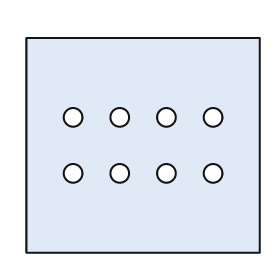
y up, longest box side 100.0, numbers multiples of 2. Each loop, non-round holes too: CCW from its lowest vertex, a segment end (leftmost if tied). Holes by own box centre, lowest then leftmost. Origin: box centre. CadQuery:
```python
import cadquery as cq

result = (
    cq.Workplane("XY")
    .moveTo(-50.0, -46.0)
    .lineTo(50.0, -46.0)
    .lineTo(50.0, 46.0)
    .lineTo(-50.0, 46.0)
    .close()
    .moveTo(-30.0, -12.0)
    .circle(4.0)
    .moveTo(-10.0, -12.0)
    .circle(4.0)
    .moveTo(10.0, -12.0)
    .circle(4.0)
    .moveTo(30.0, -12.0)
    .circle(4.0)
    .moveTo(-30.0, 12.0)
    .circle(4.0)
    .moveTo(-10.0, 12.0)
    .circle(4.0)
    .moveTo(10.0, 12.0)
    .circle(4.0)
    .moveTo(30.0, 12.0)
    .circle(4.0)
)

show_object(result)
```